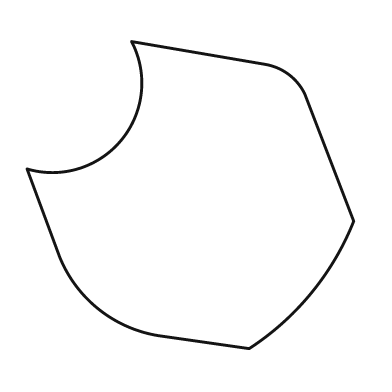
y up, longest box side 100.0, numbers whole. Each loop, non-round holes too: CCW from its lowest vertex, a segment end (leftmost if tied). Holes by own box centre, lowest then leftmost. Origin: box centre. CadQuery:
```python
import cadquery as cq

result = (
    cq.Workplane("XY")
    .moveTo(18.0, -47.0)
    .threePointArc((37.0, -30.0), (50.0, -8.0))
    .lineTo(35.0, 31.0)
    .threePointArc((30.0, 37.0), (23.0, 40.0))
    .lineTo(-18.0, 47.0)
    .threePointArc((-21.0, 17.0), (-50.0, 8.0))
    .lineTo(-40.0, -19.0)
    .threePointArc((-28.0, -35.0), (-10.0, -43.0))
    .close()
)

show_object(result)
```